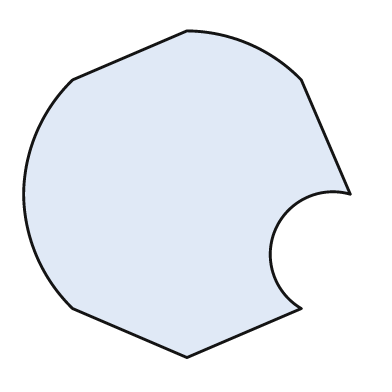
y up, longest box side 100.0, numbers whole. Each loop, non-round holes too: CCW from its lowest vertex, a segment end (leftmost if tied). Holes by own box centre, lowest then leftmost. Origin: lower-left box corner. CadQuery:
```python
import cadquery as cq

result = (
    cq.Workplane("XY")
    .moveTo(50.0, 0.0)
    .lineTo(85.0, 15.0)
    .threePointArc((77.0, 39.0), (100.0, 50.0))
    .lineTo(85.0, 85.0)
    .threePointArc((69.0, 96.0), (50.0, 100.0))
    .lineTo(15.0, 85.0)
    .threePointArc((4.0, 69.0), (0.0, 50.0))
    .threePointArc((4.0, 31.0), (15.0, 15.0))
    .close()
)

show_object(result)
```